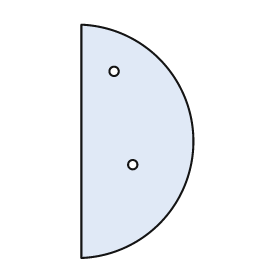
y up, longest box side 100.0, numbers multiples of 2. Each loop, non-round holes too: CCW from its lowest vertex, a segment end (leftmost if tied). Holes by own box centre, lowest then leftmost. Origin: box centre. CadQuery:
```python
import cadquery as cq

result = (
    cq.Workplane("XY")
    .moveTo(-24.0, -50.0)
    .threePointArc((24.0, 0.0), (-24.0, 50.0))
    .close()
    .moveTo(-2.0, -10.0)
    .circle(2.0)
    .moveTo(-10.0, 30.0)
    .circle(2.0)
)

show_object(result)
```